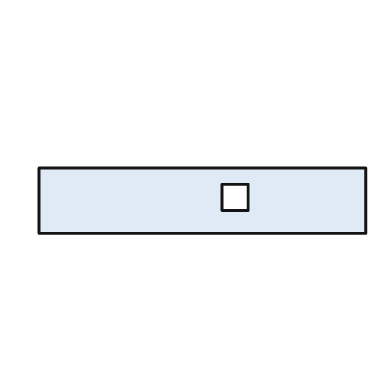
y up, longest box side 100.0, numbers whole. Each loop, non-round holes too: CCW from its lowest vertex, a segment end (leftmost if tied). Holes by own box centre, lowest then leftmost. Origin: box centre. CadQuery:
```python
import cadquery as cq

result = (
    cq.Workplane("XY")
    .moveTo(-50.0, -10.0)
    .lineTo(50.0, -10.0)
    .lineTo(50.0, 10.0)
    .lineTo(-50.0, 10.0)
    .close()
    .moveTo(6.0, -3.0)
    .lineTo(14.0, -3.0)
    .lineTo(14.0, 5.0)
    .lineTo(6.0, 5.0)
    .close()
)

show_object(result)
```